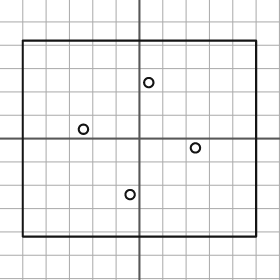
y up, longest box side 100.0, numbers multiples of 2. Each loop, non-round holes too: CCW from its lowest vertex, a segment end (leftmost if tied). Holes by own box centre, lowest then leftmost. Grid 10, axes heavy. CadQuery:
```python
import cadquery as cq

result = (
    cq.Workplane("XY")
    .moveTo(-50.0, -42.0)
    .lineTo(50.0, -42.0)
    .lineTo(50.0, 42.0)
    .lineTo(-50.0, 42.0)
    .close()
    .moveTo(-4.0, -24.0)
    .circle(2.0)
    .moveTo(24.0, -4.0)
    .circle(2.0)
    .moveTo(-24.0, 4.0)
    .circle(2.0)
    .moveTo(4.0, 24.0)
    .circle(2.0)
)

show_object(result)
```